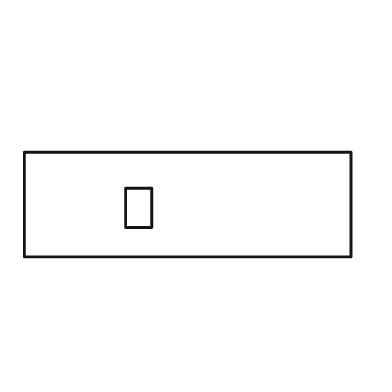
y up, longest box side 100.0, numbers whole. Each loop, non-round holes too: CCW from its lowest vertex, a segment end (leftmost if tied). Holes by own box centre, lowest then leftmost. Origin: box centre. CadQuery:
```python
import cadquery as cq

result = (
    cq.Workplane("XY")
    .moveTo(-50.0, -16.0)
    .lineTo(50.0, -16.0)
    .lineTo(50.0, 16.0)
    .lineTo(-50.0, 16.0)
    .close()
    .moveTo(-19.0, -7.0)
    .lineTo(-11.0, -7.0)
    .lineTo(-11.0, 5.0)
    .lineTo(-19.0, 5.0)
    .close()
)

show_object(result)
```